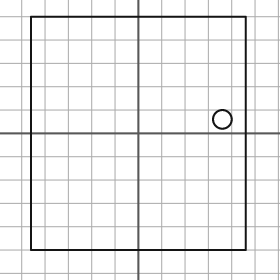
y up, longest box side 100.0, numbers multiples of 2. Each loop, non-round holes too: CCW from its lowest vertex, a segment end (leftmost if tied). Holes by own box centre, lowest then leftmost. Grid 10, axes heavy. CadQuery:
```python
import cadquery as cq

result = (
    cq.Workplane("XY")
    .moveTo(-46.0, -50.0)
    .lineTo(46.0, -50.0)
    .lineTo(46.0, 50.0)
    .lineTo(-46.0, 50.0)
    .close()
    .moveTo(36.0, 6.0)
    .circle(4.0)
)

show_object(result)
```